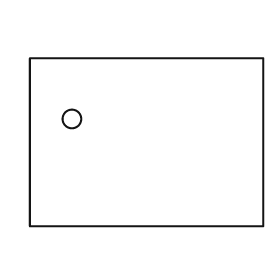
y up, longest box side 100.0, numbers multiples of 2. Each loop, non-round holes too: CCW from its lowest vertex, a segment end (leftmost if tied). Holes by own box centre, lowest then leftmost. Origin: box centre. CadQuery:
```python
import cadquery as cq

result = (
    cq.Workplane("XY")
    .moveTo(-50.0, -36.0)
    .lineTo(50.0, -36.0)
    .lineTo(50.0, 36.0)
    .lineTo(-50.0, 36.0)
    .close()
    .moveTo(-32.0, 10.0)
    .circle(4.0)
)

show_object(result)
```